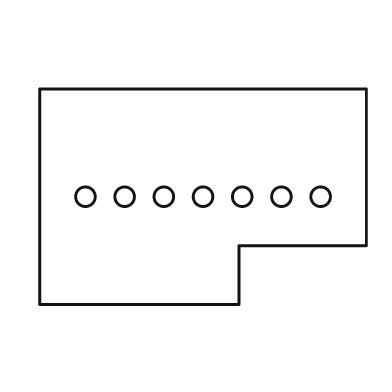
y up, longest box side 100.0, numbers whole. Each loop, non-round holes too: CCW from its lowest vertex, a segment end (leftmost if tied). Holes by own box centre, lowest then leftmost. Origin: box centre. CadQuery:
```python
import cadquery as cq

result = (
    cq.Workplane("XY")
    .moveTo(-50.0, -33.0)
    .lineTo(11.0, -33.0)
    .lineTo(11.0, -15.0)
    .lineTo(50.0, -15.0)
    .lineTo(50.0, 33.0)
    .lineTo(-50.0, 33.0)
    .close()
    .moveTo(-36.0, 0.0)
    .circle(3.0)
    .moveTo(-24.0, 0.0)
    .circle(3.0)
    .moveTo(-12.0, 0.0)
    .circle(3.0)
    .moveTo(0.0, 0.0)
    .circle(3.0)
    .moveTo(12.0, 0.0)
    .circle(3.0)
    .moveTo(24.0, 0.0)
    .circle(3.0)
    .moveTo(36.0, 0.0)
    .circle(3.0)
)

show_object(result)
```